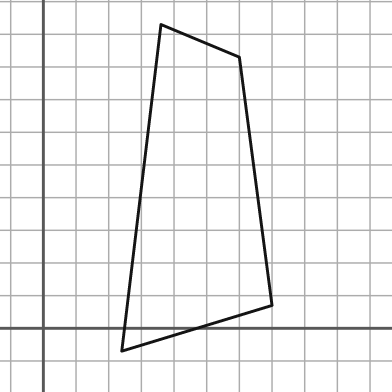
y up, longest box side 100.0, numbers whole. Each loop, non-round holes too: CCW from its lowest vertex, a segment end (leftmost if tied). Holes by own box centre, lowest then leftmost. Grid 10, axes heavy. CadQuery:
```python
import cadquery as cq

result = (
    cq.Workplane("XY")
    .moveTo(24.0, -7.0)
    .lineTo(70.0, 7.0)
    .lineTo(60.0, 83.0)
    .lineTo(36.0, 93.0)
    .close()
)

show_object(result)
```